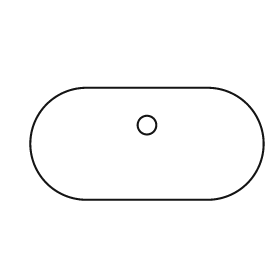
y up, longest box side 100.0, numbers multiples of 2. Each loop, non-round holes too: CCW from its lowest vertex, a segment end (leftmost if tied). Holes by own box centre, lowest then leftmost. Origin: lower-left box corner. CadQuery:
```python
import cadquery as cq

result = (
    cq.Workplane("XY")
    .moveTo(24.0, 0.0)
    .lineTo(76.0, 0.0)
    .threePointArc((100.0, 24.0), (76.0, 48.0))
    .lineTo(24.0, 48.0)
    .threePointArc((0.0, 24.0), (24.0, 0.0))
    .close()
    .moveTo(50.0, 32.0)
    .circle(4.0)
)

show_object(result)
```